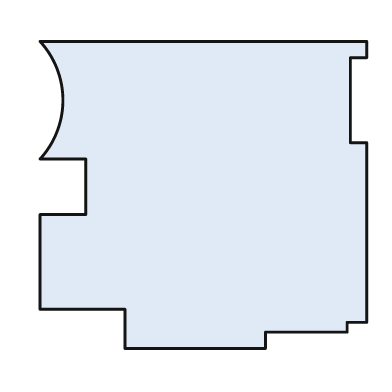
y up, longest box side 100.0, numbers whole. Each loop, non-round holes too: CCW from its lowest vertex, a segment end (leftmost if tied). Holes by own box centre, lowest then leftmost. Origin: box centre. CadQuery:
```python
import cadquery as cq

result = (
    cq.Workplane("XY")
    .moveTo(-24.0, -47.0)
    .lineTo(19.0, -47.0)
    .lineTo(19.0, -42.0)
    .lineTo(44.0, -42.0)
    .lineTo(44.0, -39.0)
    .lineTo(50.0, -39.0)
    .lineTo(50.0, 16.0)
    .lineTo(45.0, 16.0)
    .lineTo(45.0, 42.0)
    .lineTo(50.0, 42.0)
    .lineTo(50.0, 47.0)
    .lineTo(-50.0, 47.0)
    .threePointArc((-43.0, 29.0), (-50.0, 11.0))
    .lineTo(-36.0, 11.0)
    .lineTo(-36.0, -6.0)
    .lineTo(-50.0, -6.0)
    .lineTo(-50.0, -35.0)
    .lineTo(-24.0, -35.0)
    .close()
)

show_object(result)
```